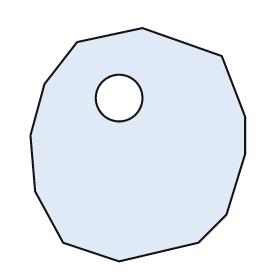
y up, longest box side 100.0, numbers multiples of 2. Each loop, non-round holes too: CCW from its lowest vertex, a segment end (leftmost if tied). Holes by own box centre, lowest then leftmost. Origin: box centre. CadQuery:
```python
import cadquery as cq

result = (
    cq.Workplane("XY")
    .moveTo(-8.0, -50.0)
    .lineTo(26.0, -42.0)
    .lineTo(38.0, -30.0)
    .lineTo(46.0, -4.0)
    .lineTo(46.0, 12.0)
    .lineTo(36.0, 38.0)
    .lineTo(2.0, 50.0)
    .lineTo(-26.0, 44.0)
    .lineTo(-40.0, 26.0)
    .lineTo(-46.0, 4.0)
    .lineTo(-44.0, -20.0)
    .lineTo(-32.0, -42.0)
    .close()
    .moveTo(-8.0, 20.0)
    .circle(10.0)
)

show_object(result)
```